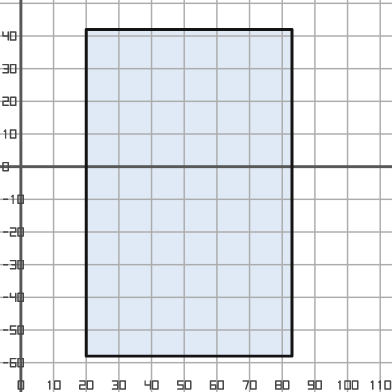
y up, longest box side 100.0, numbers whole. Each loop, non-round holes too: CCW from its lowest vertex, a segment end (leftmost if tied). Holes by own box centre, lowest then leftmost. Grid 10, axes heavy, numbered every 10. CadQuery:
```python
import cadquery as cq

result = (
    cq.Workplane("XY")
    .moveTo(20.0, -58.0)
    .lineTo(83.0, -58.0)
    .lineTo(83.0, 42.0)
    .lineTo(20.0, 42.0)
    .close()
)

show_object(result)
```